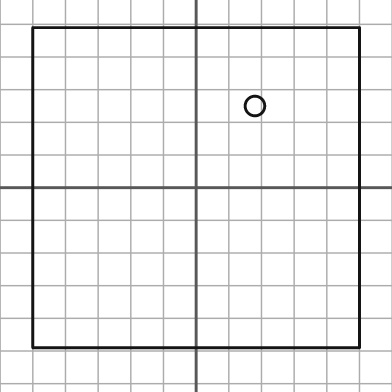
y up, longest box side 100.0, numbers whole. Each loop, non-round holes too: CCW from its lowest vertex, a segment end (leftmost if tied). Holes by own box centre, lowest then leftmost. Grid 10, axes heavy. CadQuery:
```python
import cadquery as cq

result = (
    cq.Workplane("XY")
    .moveTo(-50.0, -49.0)
    .lineTo(50.0, -49.0)
    .lineTo(50.0, 49.0)
    .lineTo(-50.0, 49.0)
    .close()
    .moveTo(18.0, 25.0)
    .circle(3.0)
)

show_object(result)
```